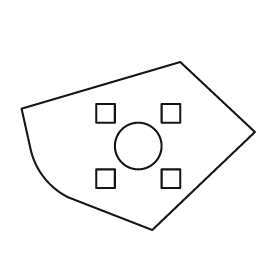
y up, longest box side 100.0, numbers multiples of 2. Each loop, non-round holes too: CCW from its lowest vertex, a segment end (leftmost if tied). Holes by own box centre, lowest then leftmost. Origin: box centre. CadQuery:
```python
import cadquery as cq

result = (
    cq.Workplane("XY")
    .moveTo(6.0, -36.0)
    .lineTo(50.0, 6.0)
    .lineTo(18.0, 36.0)
    .lineTo(-50.0, 16.0)
    .lineTo(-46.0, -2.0)
    .threePointArc((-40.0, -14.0), (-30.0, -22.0))
    .close()
    .moveTo(-18.0, -18.0)
    .lineTo(-10.0, -18.0)
    .lineTo(-10.0, -10.0)
    .lineTo(-18.0, -10.0)
    .close()
    .moveTo(10.0, -18.0)
    .lineTo(18.0, -18.0)
    .lineTo(18.0, -10.0)
    .lineTo(10.0, -10.0)
    .close()
    .moveTo(0.0, 0.0)
    .circle(10.0)
    .moveTo(-18.0, 10.0)
    .lineTo(-10.0, 10.0)
    .lineTo(-10.0, 18.0)
    .lineTo(-18.0, 18.0)
    .close()
    .moveTo(10.0, 10.0)
    .lineTo(18.0, 10.0)
    .lineTo(18.0, 18.0)
    .lineTo(10.0, 18.0)
    .close()
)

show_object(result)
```